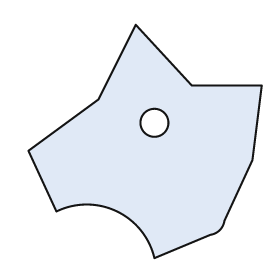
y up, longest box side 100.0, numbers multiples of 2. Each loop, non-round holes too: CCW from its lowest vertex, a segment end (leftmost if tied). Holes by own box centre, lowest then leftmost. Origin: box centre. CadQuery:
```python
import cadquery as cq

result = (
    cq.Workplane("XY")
    .moveTo(4.0, -50.0)
    .lineTo(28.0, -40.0)
    .threePointArc((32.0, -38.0), (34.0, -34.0))
    .lineTo(46.0, -8.0)
    .lineTo(50.0, 24.0)
    .lineTo(20.0, 24.0)
    .lineTo(-4.0, 50.0)
    .lineTo(-20.0, 18.0)
    .lineTo(-50.0, -4.0)
    .lineTo(-38.0, -30.0)
    .threePointArc((-12.0, -30.0), (4.0, -50.0))
    .close()
    .moveTo(4.0, 8.0)
    .circle(6.0)
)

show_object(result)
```